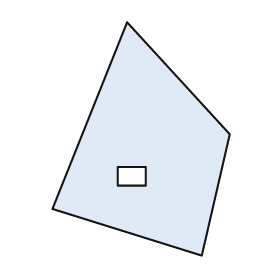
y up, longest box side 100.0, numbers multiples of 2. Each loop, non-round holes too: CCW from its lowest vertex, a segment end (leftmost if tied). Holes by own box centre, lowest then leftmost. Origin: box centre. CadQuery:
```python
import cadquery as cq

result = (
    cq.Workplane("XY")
    .moveTo(26.0, -50.0)
    .lineTo(38.0, 2.0)
    .lineTo(-6.0, 50.0)
    .lineTo(-38.0, -30.0)
    .close()
    .moveTo(-10.0, -20.0)
    .lineTo(2.0, -20.0)
    .lineTo(2.0, -12.0)
    .lineTo(-10.0, -12.0)
    .close()
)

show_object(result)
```